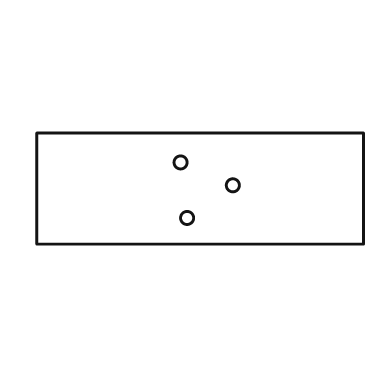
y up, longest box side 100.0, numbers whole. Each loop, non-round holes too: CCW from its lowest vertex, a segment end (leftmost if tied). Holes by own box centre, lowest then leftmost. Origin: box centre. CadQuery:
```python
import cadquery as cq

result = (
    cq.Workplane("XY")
    .moveTo(-50.0, -17.0)
    .lineTo(50.0, -17.0)
    .lineTo(50.0, 17.0)
    .lineTo(-50.0, 17.0)
    .close()
    .moveTo(-4.0, -9.0)
    .circle(2.0)
    .moveTo(10.0, 1.0)
    .circle(2.0)
    .moveTo(-6.0, 8.0)
    .circle(2.0)
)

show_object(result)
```